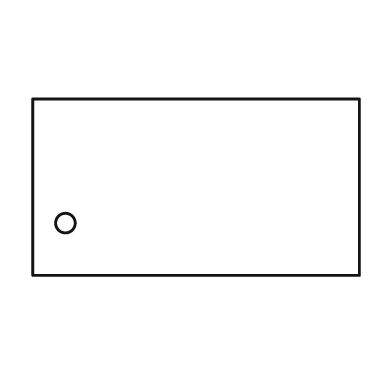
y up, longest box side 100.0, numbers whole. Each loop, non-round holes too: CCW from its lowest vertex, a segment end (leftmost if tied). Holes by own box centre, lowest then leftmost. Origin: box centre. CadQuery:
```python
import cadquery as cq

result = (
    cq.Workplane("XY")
    .moveTo(-50.0, -27.0)
    .lineTo(50.0, -27.0)
    .lineTo(50.0, 27.0)
    .lineTo(-50.0, 27.0)
    .close()
    .moveTo(-40.0, -11.0)
    .circle(3.0)
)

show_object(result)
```